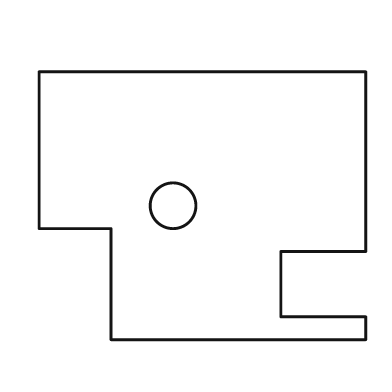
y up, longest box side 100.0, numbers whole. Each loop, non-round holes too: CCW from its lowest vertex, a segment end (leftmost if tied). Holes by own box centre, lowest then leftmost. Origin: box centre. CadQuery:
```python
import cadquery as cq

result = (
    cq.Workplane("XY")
    .moveTo(-28.0, -41.0)
    .lineTo(50.0, -41.0)
    .lineTo(50.0, -34.0)
    .lineTo(24.0, -34.0)
    .lineTo(24.0, -14.0)
    .lineTo(50.0, -14.0)
    .lineTo(50.0, 41.0)
    .lineTo(-50.0, 41.0)
    .lineTo(-50.0, -7.0)
    .lineTo(-28.0, -7.0)
    .close()
    .moveTo(-9.0, 0.0)
    .circle(7.0)
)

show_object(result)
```